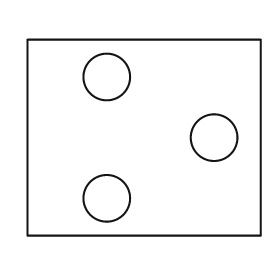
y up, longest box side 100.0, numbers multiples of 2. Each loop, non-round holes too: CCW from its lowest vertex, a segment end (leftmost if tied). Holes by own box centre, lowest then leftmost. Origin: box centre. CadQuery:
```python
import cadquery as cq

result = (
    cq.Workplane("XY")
    .moveTo(-50.0, -42.0)
    .lineTo(50.0, -42.0)
    .lineTo(50.0, 42.0)
    .lineTo(-50.0, 42.0)
    .close()
    .moveTo(-16.0, -26.0)
    .circle(10.0)
    .moveTo(30.0, 0.0)
    .circle(10.0)
    .moveTo(-16.0, 26.0)
    .circle(10.0)
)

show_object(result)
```